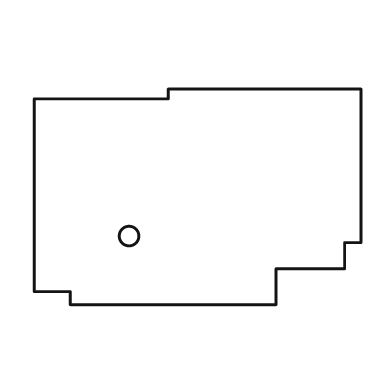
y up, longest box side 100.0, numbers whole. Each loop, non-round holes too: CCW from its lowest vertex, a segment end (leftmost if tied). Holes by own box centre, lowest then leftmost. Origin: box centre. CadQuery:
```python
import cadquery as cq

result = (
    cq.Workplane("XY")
    .moveTo(-39.0, -33.0)
    .lineTo(24.0, -33.0)
    .lineTo(24.0, -22.0)
    .lineTo(45.0, -22.0)
    .lineTo(45.0, -14.0)
    .lineTo(50.0, -14.0)
    .lineTo(50.0, 33.0)
    .lineTo(-9.0, 33.0)
    .lineTo(-9.0, 30.0)
    .lineTo(-50.0, 30.0)
    .lineTo(-50.0, -29.0)
    .lineTo(-39.0, -29.0)
    .close()
    .moveTo(-21.0, -12.0)
    .circle(3.0)
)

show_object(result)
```